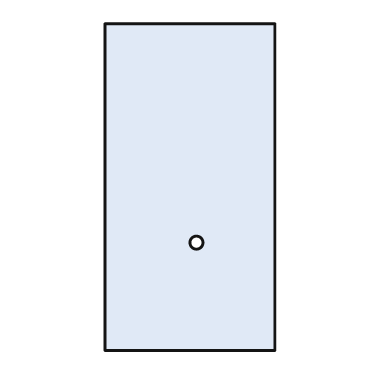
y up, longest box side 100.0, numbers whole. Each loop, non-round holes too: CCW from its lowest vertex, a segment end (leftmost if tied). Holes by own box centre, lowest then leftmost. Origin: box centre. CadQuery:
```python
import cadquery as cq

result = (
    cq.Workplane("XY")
    .moveTo(-26.0, -50.0)
    .lineTo(26.0, -50.0)
    .lineTo(26.0, 50.0)
    .lineTo(-26.0, 50.0)
    .close()
    .moveTo(2.0, -17.0)
    .circle(2.0)
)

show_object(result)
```